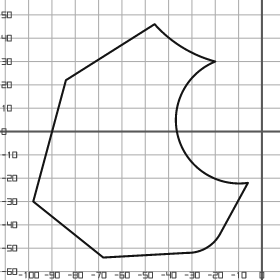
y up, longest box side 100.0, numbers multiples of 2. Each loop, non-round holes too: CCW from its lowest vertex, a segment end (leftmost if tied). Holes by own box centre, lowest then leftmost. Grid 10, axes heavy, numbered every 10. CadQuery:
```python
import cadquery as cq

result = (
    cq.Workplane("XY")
    .moveTo(-68.0, -54.0)
    .lineTo(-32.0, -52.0)
    .threePointArc((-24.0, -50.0), (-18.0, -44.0))
    .lineTo(-6.0, -22.0)
    .threePointArc((-36.0, -2.0), (-20.0, 30.0))
    .threePointArc((-34.0, 36.0), (-46.0, 46.0))
    .lineTo(-84.0, 22.0)
    .lineTo(-98.0, -30.0)
    .close()
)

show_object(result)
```